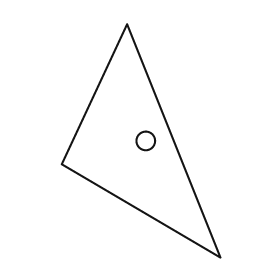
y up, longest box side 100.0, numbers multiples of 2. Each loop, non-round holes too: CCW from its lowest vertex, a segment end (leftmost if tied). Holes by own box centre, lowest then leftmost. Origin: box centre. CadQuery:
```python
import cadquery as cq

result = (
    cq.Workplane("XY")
    .moveTo(34.0, -50.0)
    .lineTo(-6.0, 50.0)
    .lineTo(-34.0, -10.0)
    .close()
    .moveTo(2.0, 0.0)
    .circle(4.0)
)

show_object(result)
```